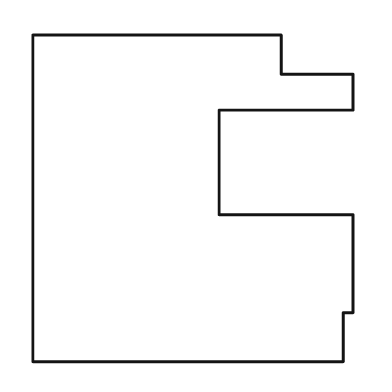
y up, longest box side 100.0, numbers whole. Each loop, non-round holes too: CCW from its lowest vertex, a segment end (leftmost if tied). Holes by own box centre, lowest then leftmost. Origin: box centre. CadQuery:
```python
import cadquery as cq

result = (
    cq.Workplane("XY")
    .moveTo(-49.0, -50.0)
    .lineTo(46.0, -50.0)
    .lineTo(46.0, -35.0)
    .lineTo(49.0, -35.0)
    .lineTo(49.0, -5.0)
    .lineTo(8.0, -5.0)
    .lineTo(8.0, 27.0)
    .lineTo(49.0, 27.0)
    .lineTo(49.0, 38.0)
    .lineTo(27.0, 38.0)
    .lineTo(27.0, 50.0)
    .lineTo(-49.0, 50.0)
    .close()
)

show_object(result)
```